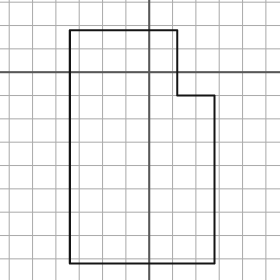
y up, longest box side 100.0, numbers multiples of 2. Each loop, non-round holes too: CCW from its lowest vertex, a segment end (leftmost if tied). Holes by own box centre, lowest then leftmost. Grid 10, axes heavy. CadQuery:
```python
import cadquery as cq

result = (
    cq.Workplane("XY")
    .moveTo(-34.0, -82.0)
    .lineTo(28.0, -82.0)
    .lineTo(28.0, -10.0)
    .lineTo(12.0, -10.0)
    .lineTo(12.0, 18.0)
    .lineTo(-34.0, 18.0)
    .close()
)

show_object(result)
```